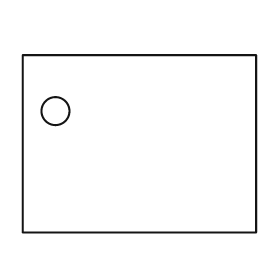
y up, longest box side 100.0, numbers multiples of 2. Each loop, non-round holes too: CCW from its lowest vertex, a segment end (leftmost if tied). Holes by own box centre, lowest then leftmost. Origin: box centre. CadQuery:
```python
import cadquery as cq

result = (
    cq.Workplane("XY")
    .moveTo(-50.0, -38.0)
    .lineTo(50.0, -38.0)
    .lineTo(50.0, 38.0)
    .lineTo(-50.0, 38.0)
    .close()
    .moveTo(-36.0, 14.0)
    .circle(6.0)
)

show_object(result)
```